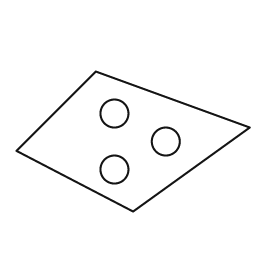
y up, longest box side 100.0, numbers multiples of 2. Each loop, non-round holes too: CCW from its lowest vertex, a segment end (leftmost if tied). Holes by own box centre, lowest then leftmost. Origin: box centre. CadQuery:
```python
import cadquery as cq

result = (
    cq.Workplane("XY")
    .moveTo(0.0, -30.0)
    .lineTo(50.0, 6.0)
    .lineTo(-16.0, 30.0)
    .lineTo(-50.0, -4.0)
    .close()
    .moveTo(-8.0, -12.0)
    .circle(6.0)
    .moveTo(14.0, 0.0)
    .circle(6.0)
    .moveTo(-8.0, 12.0)
    .circle(6.0)
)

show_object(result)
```